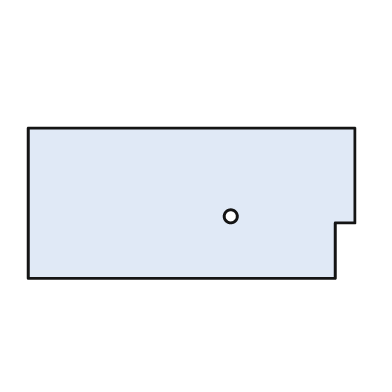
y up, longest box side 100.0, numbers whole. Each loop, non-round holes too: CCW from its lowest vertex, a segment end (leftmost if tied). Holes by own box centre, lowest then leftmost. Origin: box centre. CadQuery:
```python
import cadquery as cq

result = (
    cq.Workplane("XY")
    .moveTo(-50.0, -23.0)
    .lineTo(44.0, -23.0)
    .lineTo(44.0, -6.0)
    .lineTo(50.0, -6.0)
    .lineTo(50.0, 23.0)
    .lineTo(-50.0, 23.0)
    .close()
    .moveTo(12.0, -4.0)
    .circle(2.0)
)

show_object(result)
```